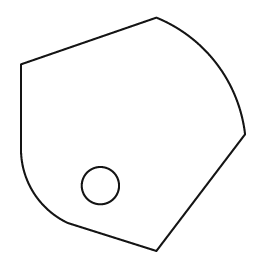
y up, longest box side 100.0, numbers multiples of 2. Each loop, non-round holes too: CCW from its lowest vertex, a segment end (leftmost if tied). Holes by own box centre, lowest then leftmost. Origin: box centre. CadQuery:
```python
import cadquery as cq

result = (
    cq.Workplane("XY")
    .moveTo(10.0, -50.0)
    .lineTo(48.0, 0.0)
    .threePointArc((36.0, 30.0), (10.0, 50.0))
    .lineTo(-48.0, 30.0)
    .lineTo(-48.0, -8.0)
    .threePointArc((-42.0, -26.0), (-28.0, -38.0))
    .close()
    .moveTo(-14.0, -22.0)
    .circle(8.0)
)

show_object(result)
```